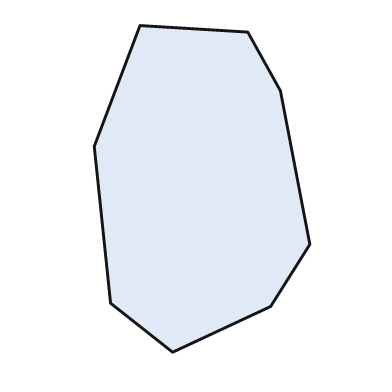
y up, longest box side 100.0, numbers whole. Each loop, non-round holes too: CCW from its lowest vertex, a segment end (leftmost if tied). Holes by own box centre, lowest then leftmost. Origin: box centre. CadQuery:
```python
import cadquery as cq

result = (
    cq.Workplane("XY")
    .moveTo(-9.0, -50.0)
    .lineTo(21.0, -36.0)
    .lineTo(33.0, -17.0)
    .lineTo(24.0, 30.0)
    .lineTo(14.0, 48.0)
    .lineTo(-19.0, 50.0)
    .lineTo(-33.0, 13.0)
    .lineTo(-28.0, -35.0)
    .close()
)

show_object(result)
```